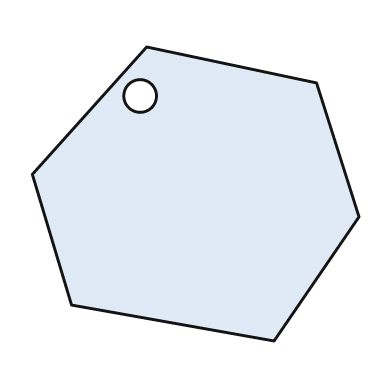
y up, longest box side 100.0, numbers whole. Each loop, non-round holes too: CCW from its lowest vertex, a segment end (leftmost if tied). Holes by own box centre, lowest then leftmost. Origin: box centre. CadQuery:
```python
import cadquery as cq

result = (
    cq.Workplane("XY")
    .moveTo(24.0, -45.0)
    .lineTo(50.0, -7.0)
    .lineTo(37.0, 34.0)
    .lineTo(-15.0, 45.0)
    .lineTo(-50.0, 6.0)
    .lineTo(-38.0, -34.0)
    .close()
    .moveTo(-17.0, 30.0)
    .circle(5.0)
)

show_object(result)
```